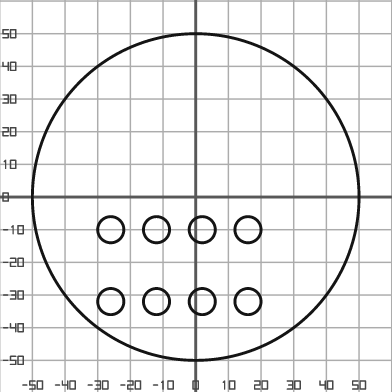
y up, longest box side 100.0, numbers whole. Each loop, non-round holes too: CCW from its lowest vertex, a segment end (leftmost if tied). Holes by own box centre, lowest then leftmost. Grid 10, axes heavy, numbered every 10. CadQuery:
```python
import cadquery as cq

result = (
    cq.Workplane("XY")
    .moveTo(0.0, 0.0)
    .circle(50.0)
    .moveTo(-26.0, -32.0)
    .circle(4.0)
    .moveTo(-12.0, -32.0)
    .circle(4.0)
    .moveTo(2.0, -32.0)
    .circle(4.0)
    .moveTo(16.0, -32.0)
    .circle(4.0)
    .moveTo(-26.0, -10.0)
    .circle(4.0)
    .moveTo(-12.0, -10.0)
    .circle(4.0)
    .moveTo(2.0, -10.0)
    .circle(4.0)
    .moveTo(16.0, -10.0)
    .circle(4.0)
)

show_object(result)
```